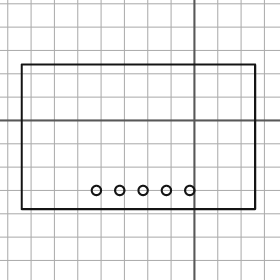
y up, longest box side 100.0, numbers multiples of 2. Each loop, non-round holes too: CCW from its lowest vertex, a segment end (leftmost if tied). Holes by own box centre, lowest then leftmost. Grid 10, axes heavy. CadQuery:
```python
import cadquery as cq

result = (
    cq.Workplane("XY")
    .moveTo(-74.0, -38.0)
    .lineTo(26.0, -38.0)
    .lineTo(26.0, 24.0)
    .lineTo(-74.0, 24.0)
    .close()
    .moveTo(-42.0, -30.0)
    .circle(2.0)
    .moveTo(-32.0, -30.0)
    .circle(2.0)
    .moveTo(-22.0, -30.0)
    .circle(2.0)
    .moveTo(-12.0, -30.0)
    .circle(2.0)
    .moveTo(-2.0, -30.0)
    .circle(2.0)
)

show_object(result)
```